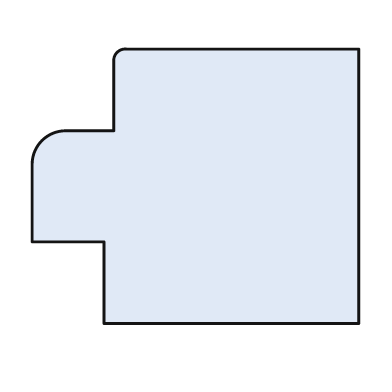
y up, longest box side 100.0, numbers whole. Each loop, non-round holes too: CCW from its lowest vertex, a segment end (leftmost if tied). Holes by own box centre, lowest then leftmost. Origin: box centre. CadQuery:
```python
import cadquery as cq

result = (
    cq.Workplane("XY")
    .moveTo(-28.0, -42.0)
    .lineTo(50.0, -42.0)
    .lineTo(50.0, 42.0)
    .lineTo(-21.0, 42.0)
    .threePointArc((-24.0, 41.0), (-25.0, 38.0))
    .lineTo(-25.0, 17.0)
    .lineTo(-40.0, 17.0)
    .threePointArc((-47.0, 14.0), (-50.0, 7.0))
    .lineTo(-50.0, -17.0)
    .lineTo(-28.0, -17.0)
    .close()
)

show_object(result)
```